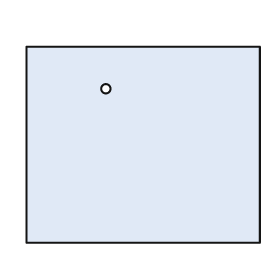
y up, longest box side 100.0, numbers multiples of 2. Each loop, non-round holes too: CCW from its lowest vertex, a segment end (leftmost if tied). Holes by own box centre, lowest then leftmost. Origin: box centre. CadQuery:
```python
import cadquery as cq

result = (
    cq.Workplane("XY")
    .moveTo(-50.0, -42.0)
    .lineTo(50.0, -42.0)
    .lineTo(50.0, 42.0)
    .lineTo(-50.0, 42.0)
    .close()
    .moveTo(-16.0, 24.0)
    .circle(2.0)
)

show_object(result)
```